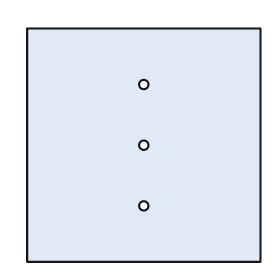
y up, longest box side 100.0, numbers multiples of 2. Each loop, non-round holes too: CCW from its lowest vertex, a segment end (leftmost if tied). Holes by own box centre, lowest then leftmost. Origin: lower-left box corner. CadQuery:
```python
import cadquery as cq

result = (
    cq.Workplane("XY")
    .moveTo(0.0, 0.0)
    .lineTo(100.0, 0.0)
    .lineTo(100.0, 100.0)
    .lineTo(0.0, 100.0)
    .close()
    .moveTo(50.0, 24.0)
    .circle(2.0)
    .moveTo(50.0, 50.0)
    .circle(2.0)
    .moveTo(50.0, 76.0)
    .circle(2.0)
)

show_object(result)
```